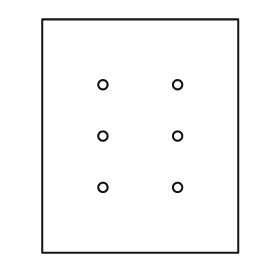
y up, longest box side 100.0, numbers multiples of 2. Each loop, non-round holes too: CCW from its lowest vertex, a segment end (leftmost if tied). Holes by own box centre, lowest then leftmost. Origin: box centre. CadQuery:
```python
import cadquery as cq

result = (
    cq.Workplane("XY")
    .moveTo(-42.0, -50.0)
    .lineTo(42.0, -50.0)
    .lineTo(42.0, 50.0)
    .lineTo(-42.0, 50.0)
    .close()
    .moveTo(-16.0, -22.0)
    .circle(2.0)
    .moveTo(16.0, -22.0)
    .circle(2.0)
    .moveTo(-16.0, 0.0)
    .circle(2.0)
    .moveTo(16.0, 0.0)
    .circle(2.0)
    .moveTo(-16.0, 22.0)
    .circle(2.0)
    .moveTo(16.0, 22.0)
    .circle(2.0)
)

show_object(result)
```